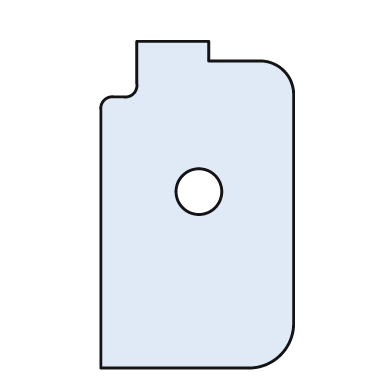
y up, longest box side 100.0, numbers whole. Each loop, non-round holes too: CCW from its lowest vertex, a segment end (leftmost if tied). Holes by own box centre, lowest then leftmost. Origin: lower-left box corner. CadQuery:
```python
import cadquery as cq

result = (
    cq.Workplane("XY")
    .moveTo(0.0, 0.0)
    .lineTo(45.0, 0.0)
    .threePointArc((55.0, 4.0), (59.0, 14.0))
    .lineTo(59.0, 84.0)
    .threePointArc((56.0, 91.0), (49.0, 94.0))
    .lineTo(33.0, 94.0)
    .lineTo(33.0, 100.0)
    .lineTo(11.0, 100.0)
    .lineTo(11.0, 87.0)
    .threePointArc((10.0, 84.0), (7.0, 83.0))
    .lineTo(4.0, 83.0)
    .threePointArc((1.0, 82.0), (0.0, 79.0))
    .close()
    .moveTo(30.0, 54.0)
    .circle(7.0)
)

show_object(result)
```